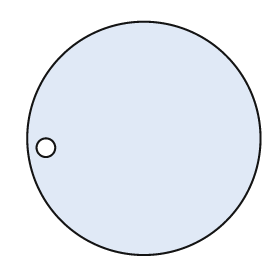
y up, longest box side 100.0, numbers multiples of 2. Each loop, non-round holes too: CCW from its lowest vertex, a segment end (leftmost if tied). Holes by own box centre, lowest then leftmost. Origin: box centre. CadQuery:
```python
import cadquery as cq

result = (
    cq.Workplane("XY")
    .moveTo(0.0, 0.0)
    .circle(50.0)
    .moveTo(-42.0, -4.0)
    .circle(4.0)
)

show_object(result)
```